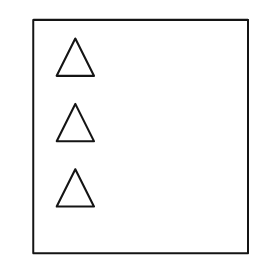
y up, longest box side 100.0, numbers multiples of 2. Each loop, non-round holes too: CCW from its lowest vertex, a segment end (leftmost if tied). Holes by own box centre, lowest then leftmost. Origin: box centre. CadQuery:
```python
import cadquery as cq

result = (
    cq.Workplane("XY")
    .moveTo(-46.0, -50.0)
    .lineTo(46.0, -50.0)
    .lineTo(46.0, 50.0)
    .lineTo(-46.0, 50.0)
    .close()
    .moveTo(-36.0, -30.0)
    .lineTo(-20.0, -30.0)
    .lineTo(-28.0, -14.0)
    .close()
    .moveTo(-36.0, -2.0)
    .lineTo(-20.0, -2.0)
    .lineTo(-28.0, 14.0)
    .close()
    .moveTo(-36.0, 26.0)
    .lineTo(-20.0, 26.0)
    .lineTo(-28.0, 42.0)
    .close()
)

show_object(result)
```